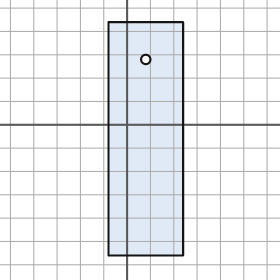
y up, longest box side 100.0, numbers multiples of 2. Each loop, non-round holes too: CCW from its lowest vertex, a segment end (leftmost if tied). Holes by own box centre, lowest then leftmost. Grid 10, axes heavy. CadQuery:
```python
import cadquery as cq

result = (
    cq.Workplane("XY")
    .moveTo(-8.0, -56.0)
    .lineTo(24.0, -56.0)
    .lineTo(24.0, 44.0)
    .lineTo(-8.0, 44.0)
    .close()
    .moveTo(8.0, 28.0)
    .circle(2.0)
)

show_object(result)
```